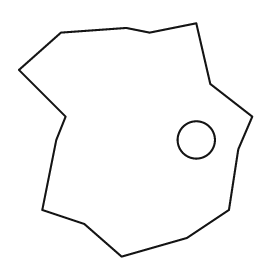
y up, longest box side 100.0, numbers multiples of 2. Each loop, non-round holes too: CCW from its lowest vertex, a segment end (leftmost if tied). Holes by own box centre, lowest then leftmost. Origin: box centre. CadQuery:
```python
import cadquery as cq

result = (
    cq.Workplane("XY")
    .moveTo(-6.0, -50.0)
    .lineTo(22.0, -42.0)
    .lineTo(40.0, -30.0)
    .lineTo(44.0, -4.0)
    .lineTo(50.0, 10.0)
    .lineTo(32.0, 24.0)
    .lineTo(26.0, 50.0)
    .lineTo(6.0, 46.0)
    .lineTo(-4.0, 48.0)
    .lineTo(-32.0, 46.0)
    .lineTo(-50.0, 30.0)
    .lineTo(-30.0, 10.0)
    .lineTo(-34.0, 0.0)
    .lineTo(-40.0, -30.0)
    .lineTo(-22.0, -36.0)
    .close()
    .moveTo(26.0, 0.0)
    .circle(8.0)
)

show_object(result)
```